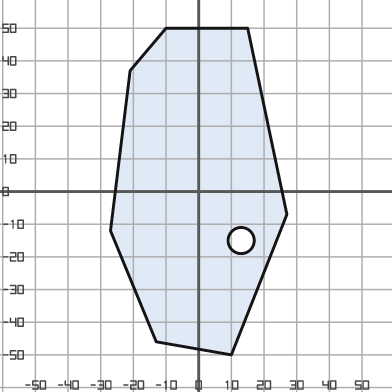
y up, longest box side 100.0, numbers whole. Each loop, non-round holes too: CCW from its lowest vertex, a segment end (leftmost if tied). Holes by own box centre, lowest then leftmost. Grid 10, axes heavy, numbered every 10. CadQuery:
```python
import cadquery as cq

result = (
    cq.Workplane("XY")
    .moveTo(10.0, -50.0)
    .lineTo(27.0, -7.0)
    .lineTo(15.0, 50.0)
    .lineTo(-10.0, 50.0)
    .lineTo(-21.0, 37.0)
    .lineTo(-27.0, -12.0)
    .lineTo(-13.0, -46.0)
    .close()
    .moveTo(13.0, -15.0)
    .circle(4.0)
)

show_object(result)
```